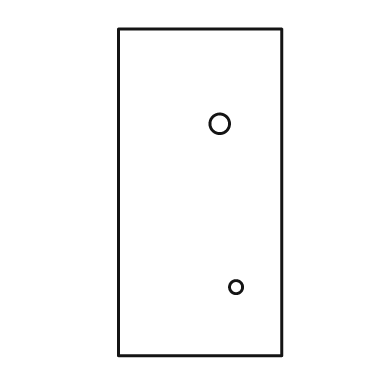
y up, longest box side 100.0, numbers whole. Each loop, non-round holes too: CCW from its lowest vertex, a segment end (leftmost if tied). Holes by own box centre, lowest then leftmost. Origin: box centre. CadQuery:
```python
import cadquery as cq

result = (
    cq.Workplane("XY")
    .moveTo(-25.0, -50.0)
    .lineTo(25.0, -50.0)
    .lineTo(25.0, 50.0)
    .lineTo(-25.0, 50.0)
    .close()
    .moveTo(11.0, -29.0)
    .circle(2.0)
    .moveTo(6.0, 21.0)
    .circle(3.0)
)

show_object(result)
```